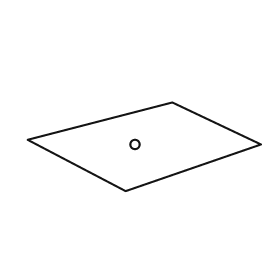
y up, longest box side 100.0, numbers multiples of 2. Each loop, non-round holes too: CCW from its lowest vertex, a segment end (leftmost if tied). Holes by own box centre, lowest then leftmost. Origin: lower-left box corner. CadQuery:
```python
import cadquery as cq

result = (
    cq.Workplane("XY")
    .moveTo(42.0, 0.0)
    .lineTo(100.0, 20.0)
    .lineTo(62.0, 38.0)
    .lineTo(0.0, 22.0)
    .close()
    .moveTo(46.0, 20.0)
    .circle(2.0)
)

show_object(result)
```